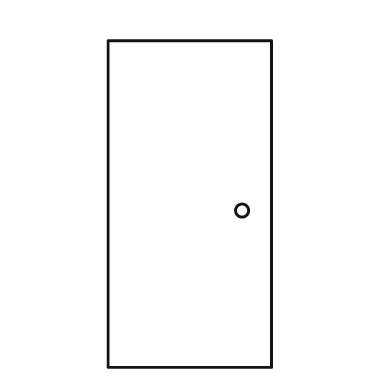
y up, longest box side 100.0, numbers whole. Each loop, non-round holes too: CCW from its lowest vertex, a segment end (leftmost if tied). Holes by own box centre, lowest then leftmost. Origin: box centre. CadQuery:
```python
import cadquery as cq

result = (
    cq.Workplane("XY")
    .moveTo(-25.0, -50.0)
    .lineTo(25.0, -50.0)
    .lineTo(25.0, 50.0)
    .lineTo(-25.0, 50.0)
    .close()
    .moveTo(16.0, -2.0)
    .circle(2.0)
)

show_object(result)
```